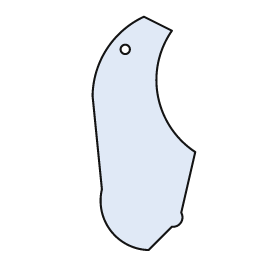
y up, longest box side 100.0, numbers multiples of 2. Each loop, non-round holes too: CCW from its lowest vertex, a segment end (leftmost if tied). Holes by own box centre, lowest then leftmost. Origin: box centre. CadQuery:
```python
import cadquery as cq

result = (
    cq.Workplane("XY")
    .moveTo(2.0, -50.0)
    .lineTo(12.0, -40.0)
    .threePointArc((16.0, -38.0), (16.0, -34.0))
    .lineTo(22.0, -8.0)
    .threePointArc((6.0, 16.0), (12.0, 44.0))
    .lineTo(0.0, 50.0)
    .threePointArc((-16.0, 36.0), (-22.0, 16.0))
    .lineTo(-18.0, -24.0)
    .threePointArc((-14.0, -42.0), (2.0, -50.0))
    .close()
    .moveTo(-8.0, 36.0)
    .circle(2.0)
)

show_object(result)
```